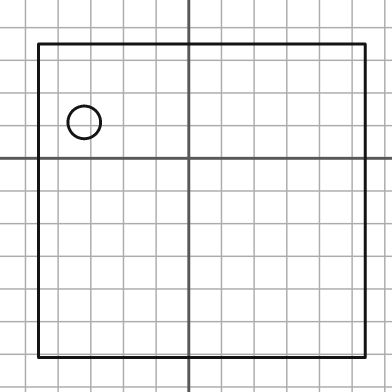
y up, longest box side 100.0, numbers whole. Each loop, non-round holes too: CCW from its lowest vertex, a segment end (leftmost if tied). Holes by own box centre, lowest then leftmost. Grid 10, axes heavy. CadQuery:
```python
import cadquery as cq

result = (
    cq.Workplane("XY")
    .moveTo(-46.0, -61.0)
    .lineTo(54.0, -61.0)
    .lineTo(54.0, 35.0)
    .lineTo(-46.0, 35.0)
    .close()
    .moveTo(-32.0, 11.0)
    .circle(5.0)
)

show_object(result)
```